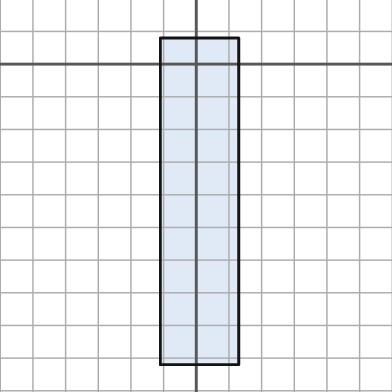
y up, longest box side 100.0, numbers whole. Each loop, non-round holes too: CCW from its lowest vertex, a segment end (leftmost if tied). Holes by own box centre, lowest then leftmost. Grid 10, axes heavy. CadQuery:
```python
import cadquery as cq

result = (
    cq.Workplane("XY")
    .moveTo(-11.0, -92.0)
    .lineTo(13.0, -92.0)
    .lineTo(13.0, 8.0)
    .lineTo(-11.0, 8.0)
    .close()
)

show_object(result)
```